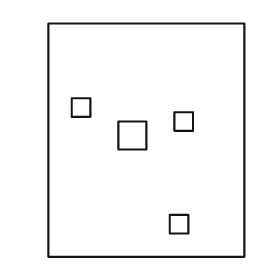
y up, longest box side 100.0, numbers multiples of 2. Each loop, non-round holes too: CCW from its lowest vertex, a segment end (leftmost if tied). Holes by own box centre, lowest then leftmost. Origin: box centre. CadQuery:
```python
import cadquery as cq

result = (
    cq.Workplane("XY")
    .moveTo(-42.0, -50.0)
    .lineTo(42.0, -50.0)
    .lineTo(42.0, 50.0)
    .lineTo(-42.0, 50.0)
    .close()
    .moveTo(10.0, -40.0)
    .lineTo(18.0, -40.0)
    .lineTo(18.0, -32.0)
    .lineTo(10.0, -32.0)
    .close()
    .moveTo(-12.0, -4.0)
    .lineTo(0.0, -4.0)
    .lineTo(0.0, 8.0)
    .lineTo(-12.0, 8.0)
    .close()
    .moveTo(12.0, 4.0)
    .lineTo(20.0, 4.0)
    .lineTo(20.0, 12.0)
    .lineTo(12.0, 12.0)
    .close()
    .moveTo(-32.0, 10.0)
    .lineTo(-24.0, 10.0)
    .lineTo(-24.0, 18.0)
    .lineTo(-32.0, 18.0)
    .close()
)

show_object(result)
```